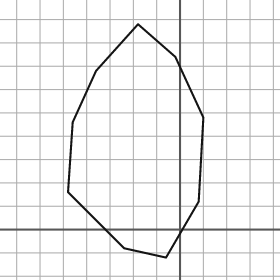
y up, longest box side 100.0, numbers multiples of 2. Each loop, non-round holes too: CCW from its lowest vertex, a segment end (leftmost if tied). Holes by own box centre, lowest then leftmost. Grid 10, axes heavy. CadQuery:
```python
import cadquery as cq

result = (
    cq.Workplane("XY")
    .moveTo(-6.0, -12.0)
    .lineTo(8.0, 12.0)
    .lineTo(10.0, 48.0)
    .lineTo(-2.0, 74.0)
    .lineTo(-18.0, 88.0)
    .lineTo(-36.0, 68.0)
    .lineTo(-46.0, 46.0)
    .lineTo(-48.0, 16.0)
    .lineTo(-24.0, -8.0)
    .close()
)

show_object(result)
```